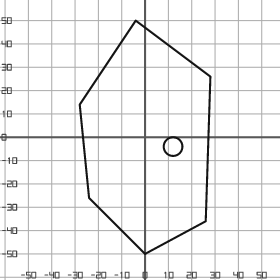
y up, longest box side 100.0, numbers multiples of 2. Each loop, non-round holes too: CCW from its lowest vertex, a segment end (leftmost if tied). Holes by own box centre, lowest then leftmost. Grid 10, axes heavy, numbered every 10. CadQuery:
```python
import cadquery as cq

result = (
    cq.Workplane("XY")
    .moveTo(0.0, -50.0)
    .lineTo(26.0, -36.0)
    .lineTo(28.0, 26.0)
    .lineTo(-4.0, 50.0)
    .lineTo(-28.0, 14.0)
    .lineTo(-24.0, -26.0)
    .close()
    .moveTo(12.0, -4.0)
    .circle(4.0)
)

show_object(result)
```